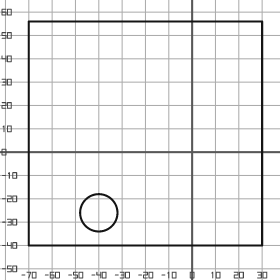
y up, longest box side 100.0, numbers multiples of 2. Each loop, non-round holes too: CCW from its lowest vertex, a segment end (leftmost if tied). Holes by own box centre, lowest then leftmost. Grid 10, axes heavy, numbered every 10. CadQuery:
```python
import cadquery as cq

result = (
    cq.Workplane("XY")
    .moveTo(-70.0, -40.0)
    .lineTo(30.0, -40.0)
    .lineTo(30.0, 56.0)
    .lineTo(-70.0, 56.0)
    .close()
    .moveTo(-40.0, -26.0)
    .circle(8.0)
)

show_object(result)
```